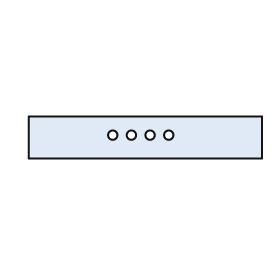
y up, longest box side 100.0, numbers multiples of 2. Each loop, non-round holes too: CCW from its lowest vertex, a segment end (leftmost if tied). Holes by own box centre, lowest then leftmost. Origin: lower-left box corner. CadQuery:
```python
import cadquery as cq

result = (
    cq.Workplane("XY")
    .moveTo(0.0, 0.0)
    .lineTo(100.0, 0.0)
    .lineTo(100.0, 18.0)
    .lineTo(0.0, 18.0)
    .close()
    .moveTo(36.0, 10.0)
    .circle(2.0)
    .moveTo(44.0, 10.0)
    .circle(2.0)
    .moveTo(52.0, 10.0)
    .circle(2.0)
    .moveTo(60.0, 10.0)
    .circle(2.0)
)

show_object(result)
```